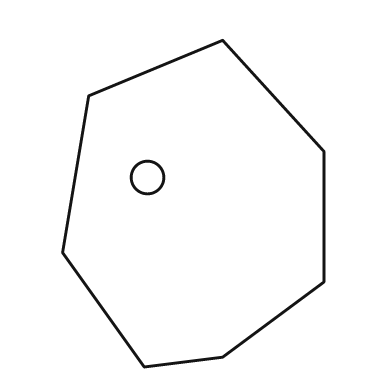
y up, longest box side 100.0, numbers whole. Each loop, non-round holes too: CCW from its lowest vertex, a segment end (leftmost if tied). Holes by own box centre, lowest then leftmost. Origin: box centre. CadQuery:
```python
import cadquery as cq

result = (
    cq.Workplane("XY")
    .moveTo(-15.0, -50.0)
    .lineTo(9.0, -47.0)
    .lineTo(40.0, -24.0)
    .lineTo(40.0, 16.0)
    .lineTo(9.0, 50.0)
    .lineTo(-32.0, 33.0)
    .lineTo(-40.0, -15.0)
    .close()
    .moveTo(-14.0, 8.0)
    .circle(5.0)
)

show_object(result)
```